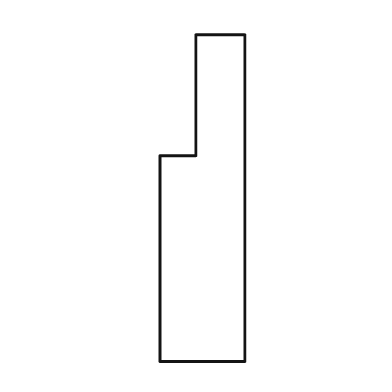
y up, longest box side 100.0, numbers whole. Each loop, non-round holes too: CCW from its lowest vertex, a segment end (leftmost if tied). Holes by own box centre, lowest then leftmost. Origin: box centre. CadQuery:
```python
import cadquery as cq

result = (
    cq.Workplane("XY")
    .moveTo(-13.0, -50.0)
    .lineTo(13.0, -50.0)
    .lineTo(13.0, 50.0)
    .lineTo(-2.0, 50.0)
    .lineTo(-2.0, 13.0)
    .lineTo(-13.0, 13.0)
    .close()
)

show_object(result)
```